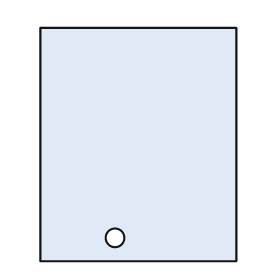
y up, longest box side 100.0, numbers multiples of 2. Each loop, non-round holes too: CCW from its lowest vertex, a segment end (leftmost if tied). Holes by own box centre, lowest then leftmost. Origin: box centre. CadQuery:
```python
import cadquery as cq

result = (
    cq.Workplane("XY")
    .moveTo(-42.0, -50.0)
    .lineTo(42.0, -50.0)
    .lineTo(42.0, 50.0)
    .lineTo(-42.0, 50.0)
    .close()
    .moveTo(-10.0, -40.0)
    .circle(4.0)
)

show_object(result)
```